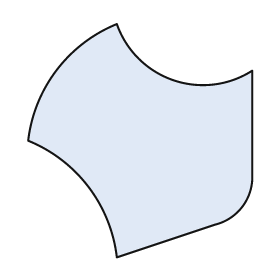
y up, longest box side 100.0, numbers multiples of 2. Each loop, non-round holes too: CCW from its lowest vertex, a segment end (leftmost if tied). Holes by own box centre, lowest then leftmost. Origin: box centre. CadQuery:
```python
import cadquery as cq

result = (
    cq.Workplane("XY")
    .moveTo(-10.0, -50.0)
    .lineTo(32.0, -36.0)
    .threePointArc((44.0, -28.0), (48.0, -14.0))
    .lineTo(48.0, 30.0)
    .threePointArc((14.0, 26.0), (-10.0, 50.0))
    .threePointArc((-36.0, 30.0), (-48.0, 0.0))
    .threePointArc((-22.0, -20.0), (-10.0, -50.0))
    .close()
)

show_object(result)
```